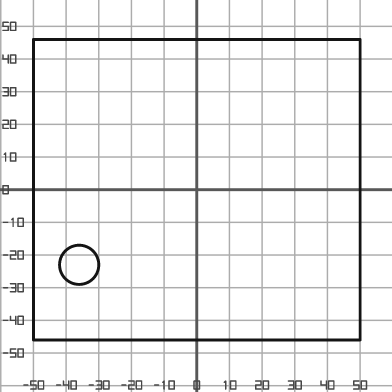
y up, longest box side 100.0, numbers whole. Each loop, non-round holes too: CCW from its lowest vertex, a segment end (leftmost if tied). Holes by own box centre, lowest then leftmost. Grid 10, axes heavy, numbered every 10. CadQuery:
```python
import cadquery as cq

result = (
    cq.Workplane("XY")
    .moveTo(-50.0, -46.0)
    .lineTo(50.0, -46.0)
    .lineTo(50.0, 46.0)
    .lineTo(-50.0, 46.0)
    .close()
    .moveTo(-36.0, -23.0)
    .circle(6.0)
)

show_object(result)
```